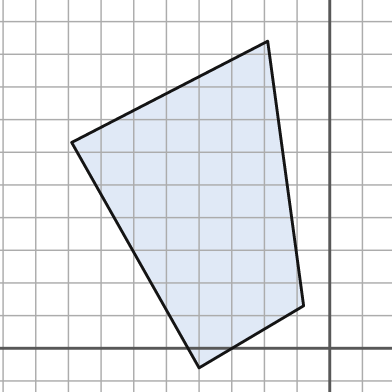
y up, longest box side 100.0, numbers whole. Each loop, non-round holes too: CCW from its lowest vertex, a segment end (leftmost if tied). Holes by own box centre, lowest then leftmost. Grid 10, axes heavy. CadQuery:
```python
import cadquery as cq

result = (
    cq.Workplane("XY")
    .moveTo(-40.0, -6.0)
    .lineTo(-8.0, 13.0)
    .lineTo(-19.0, 94.0)
    .lineTo(-79.0, 63.0)
    .close()
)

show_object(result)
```